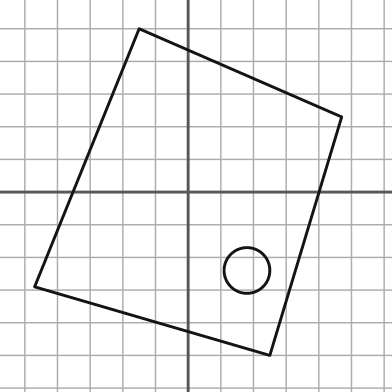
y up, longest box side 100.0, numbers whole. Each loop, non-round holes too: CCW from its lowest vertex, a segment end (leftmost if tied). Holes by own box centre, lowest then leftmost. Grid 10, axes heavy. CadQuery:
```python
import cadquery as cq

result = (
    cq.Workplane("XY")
    .moveTo(25.0, -50.0)
    .lineTo(47.0, 23.0)
    .lineTo(-15.0, 50.0)
    .lineTo(-47.0, -29.0)
    .close()
    .moveTo(18.0, -24.0)
    .circle(7.0)
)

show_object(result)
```